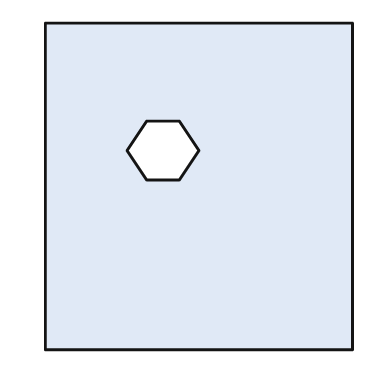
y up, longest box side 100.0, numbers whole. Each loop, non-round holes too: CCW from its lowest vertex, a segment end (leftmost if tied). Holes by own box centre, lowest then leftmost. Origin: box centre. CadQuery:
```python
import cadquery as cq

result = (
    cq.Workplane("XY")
    .moveTo(-47.0, -50.0)
    .lineTo(47.0, -50.0)
    .lineTo(47.0, 50.0)
    .lineTo(-47.0, 50.0)
    .close()
    .moveTo(-16.0, 2.0)
    .lineTo(-6.0, 2.0)
    .lineTo(0.0, 11.0)
    .lineTo(-6.0, 20.0)
    .lineTo(-16.0, 20.0)
    .lineTo(-22.0, 11.0)
    .close()
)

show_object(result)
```